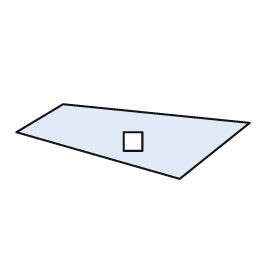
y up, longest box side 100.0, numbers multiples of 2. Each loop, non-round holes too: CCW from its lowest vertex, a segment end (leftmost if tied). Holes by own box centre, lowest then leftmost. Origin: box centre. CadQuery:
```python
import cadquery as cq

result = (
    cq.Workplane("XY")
    .moveTo(20.0, -16.0)
    .lineTo(50.0, 8.0)
    .lineTo(-30.0, 16.0)
    .lineTo(-50.0, 4.0)
    .close()
    .moveTo(-4.0, -4.0)
    .lineTo(4.0, -4.0)
    .lineTo(4.0, 4.0)
    .lineTo(-4.0, 4.0)
    .close()
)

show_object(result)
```